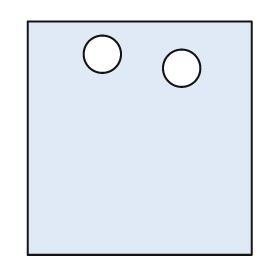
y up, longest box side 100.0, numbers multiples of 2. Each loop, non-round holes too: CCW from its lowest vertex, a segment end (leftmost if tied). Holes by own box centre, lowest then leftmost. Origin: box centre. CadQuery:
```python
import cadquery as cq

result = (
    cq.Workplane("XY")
    .moveTo(-48.0, -50.0)
    .lineTo(48.0, -50.0)
    .lineTo(48.0, 50.0)
    .lineTo(-48.0, 50.0)
    .close()
    .moveTo(18.0, 30.0)
    .circle(8.0)
    .moveTo(-16.0, 36.0)
    .circle(8.0)
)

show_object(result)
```